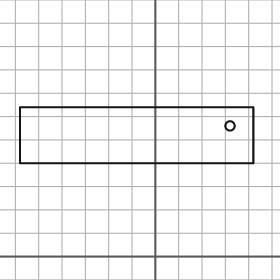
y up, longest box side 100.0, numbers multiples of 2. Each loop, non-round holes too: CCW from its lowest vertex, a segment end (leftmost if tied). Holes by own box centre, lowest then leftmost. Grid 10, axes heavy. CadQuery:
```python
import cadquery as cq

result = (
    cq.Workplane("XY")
    .moveTo(-58.0, 40.0)
    .lineTo(42.0, 40.0)
    .lineTo(42.0, 64.0)
    .lineTo(-58.0, 64.0)
    .close()
    .moveTo(32.0, 56.0)
    .circle(2.0)
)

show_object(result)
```